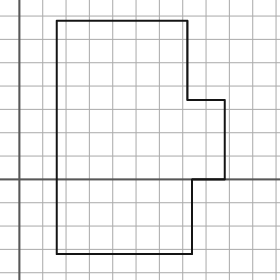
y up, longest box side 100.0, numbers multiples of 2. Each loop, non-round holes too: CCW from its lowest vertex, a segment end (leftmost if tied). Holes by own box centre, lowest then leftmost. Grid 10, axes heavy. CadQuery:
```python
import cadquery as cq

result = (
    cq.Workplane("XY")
    .moveTo(16.0, -32.0)
    .lineTo(74.0, -32.0)
    .lineTo(74.0, 0.0)
    .lineTo(88.0, 0.0)
    .lineTo(88.0, 34.0)
    .lineTo(72.0, 34.0)
    .lineTo(72.0, 68.0)
    .lineTo(16.0, 68.0)
    .close()
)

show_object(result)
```